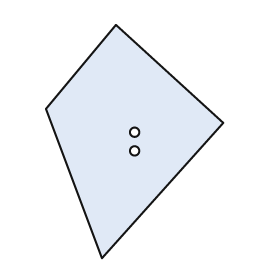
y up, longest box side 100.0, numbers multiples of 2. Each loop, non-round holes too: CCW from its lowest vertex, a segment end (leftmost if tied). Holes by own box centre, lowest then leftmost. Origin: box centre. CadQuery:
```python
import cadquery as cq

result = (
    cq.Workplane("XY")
    .moveTo(-14.0, -50.0)
    .lineTo(38.0, 8.0)
    .lineTo(-8.0, 50.0)
    .lineTo(-38.0, 14.0)
    .close()
    .moveTo(0.0, -4.0)
    .circle(2.0)
    .moveTo(0.0, 4.0)
    .circle(2.0)
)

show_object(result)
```